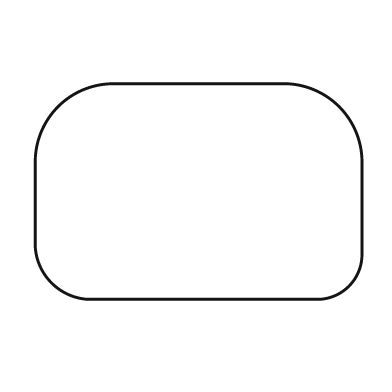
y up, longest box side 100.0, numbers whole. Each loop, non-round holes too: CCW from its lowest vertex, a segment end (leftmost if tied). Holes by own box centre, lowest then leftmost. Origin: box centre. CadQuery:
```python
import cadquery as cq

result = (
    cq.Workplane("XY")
    .moveTo(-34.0, -33.0)
    .lineTo(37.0, -33.0)
    .threePointArc((46.0, -29.0), (50.0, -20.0))
    .lineTo(50.0, 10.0)
    .threePointArc((43.0, 26.0), (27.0, 33.0))
    .lineTo(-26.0, 33.0)
    .threePointArc((-43.0, 26.0), (-50.0, 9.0))
    .lineTo(-50.0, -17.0)
    .threePointArc((-45.0, -28.0), (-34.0, -33.0))
    .close()
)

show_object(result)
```